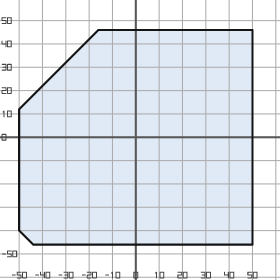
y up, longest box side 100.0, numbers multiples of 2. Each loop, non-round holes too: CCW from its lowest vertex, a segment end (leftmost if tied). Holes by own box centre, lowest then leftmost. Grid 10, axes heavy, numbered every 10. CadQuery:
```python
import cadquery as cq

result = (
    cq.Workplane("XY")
    .moveTo(-44.0, -46.0)
    .lineTo(50.0, -46.0)
    .lineTo(50.0, 46.0)
    .lineTo(-16.0, 46.0)
    .lineTo(-50.0, 12.0)
    .lineTo(-50.0, -40.0)
    .close()
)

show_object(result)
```